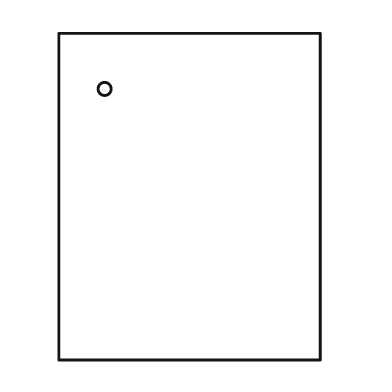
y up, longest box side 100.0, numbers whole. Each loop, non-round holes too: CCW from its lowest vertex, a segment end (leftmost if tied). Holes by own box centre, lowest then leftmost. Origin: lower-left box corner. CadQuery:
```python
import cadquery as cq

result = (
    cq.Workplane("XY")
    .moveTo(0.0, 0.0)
    .lineTo(80.0, 0.0)
    .lineTo(80.0, 100.0)
    .lineTo(0.0, 100.0)
    .close()
    .moveTo(14.0, 83.0)
    .circle(2.0)
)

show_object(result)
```